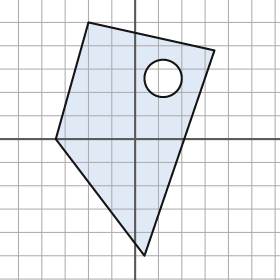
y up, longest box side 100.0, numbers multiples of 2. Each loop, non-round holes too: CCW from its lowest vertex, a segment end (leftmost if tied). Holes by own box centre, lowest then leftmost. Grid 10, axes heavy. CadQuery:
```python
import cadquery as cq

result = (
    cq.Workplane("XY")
    .moveTo(4.0, -50.0)
    .lineTo(34.0, 38.0)
    .lineTo(-20.0, 50.0)
    .lineTo(-34.0, 0.0)
    .close()
    .moveTo(12.0, 26.0)
    .circle(8.0)
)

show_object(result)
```